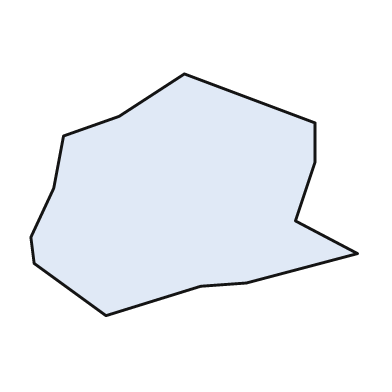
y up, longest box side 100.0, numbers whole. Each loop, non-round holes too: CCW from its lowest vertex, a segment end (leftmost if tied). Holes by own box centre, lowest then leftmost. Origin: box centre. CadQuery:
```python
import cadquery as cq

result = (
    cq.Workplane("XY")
    .moveTo(-27.0, -37.0)
    .lineTo(2.0, -28.0)
    .lineTo(16.0, -27.0)
    .lineTo(50.0, -18.0)
    .lineTo(31.0, -8.0)
    .lineTo(37.0, 10.0)
    .lineTo(37.0, 22.0)
    .lineTo(-3.0, 37.0)
    .lineTo(-23.0, 24.0)
    .lineTo(-40.0, 18.0)
    .lineTo(-43.0, 2.0)
    .lineTo(-50.0, -13.0)
    .lineTo(-49.0, -21.0)
    .close()
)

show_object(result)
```